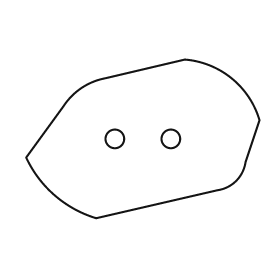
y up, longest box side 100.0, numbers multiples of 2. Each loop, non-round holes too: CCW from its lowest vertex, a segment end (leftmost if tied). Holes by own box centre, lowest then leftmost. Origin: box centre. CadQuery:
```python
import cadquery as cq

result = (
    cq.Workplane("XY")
    .moveTo(-20.0, -34.0)
    .lineTo(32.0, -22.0)
    .threePointArc((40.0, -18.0), (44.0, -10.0))
    .lineTo(50.0, 8.0)
    .threePointArc((38.0, 26.0), (18.0, 34.0))
    .lineTo(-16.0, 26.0)
    .threePointArc((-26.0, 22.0), (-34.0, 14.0))
    .lineTo(-50.0, -8.0)
    .threePointArc((-38.0, -24.0), (-20.0, -34.0))
    .close()
    .moveTo(-12.0, 0.0)
    .circle(4.0)
    .moveTo(12.0, 0.0)
    .circle(4.0)
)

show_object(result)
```